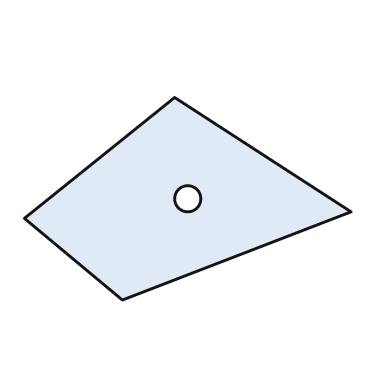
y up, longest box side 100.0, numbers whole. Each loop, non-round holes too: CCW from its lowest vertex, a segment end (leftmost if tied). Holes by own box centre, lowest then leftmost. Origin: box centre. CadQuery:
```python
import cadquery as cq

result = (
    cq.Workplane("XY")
    .moveTo(-20.0, -31.0)
    .lineTo(50.0, -4.0)
    .lineTo(-4.0, 31.0)
    .lineTo(-50.0, -6.0)
    .close()
    .moveTo(0.0, 0.0)
    .circle(4.0)
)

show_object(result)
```